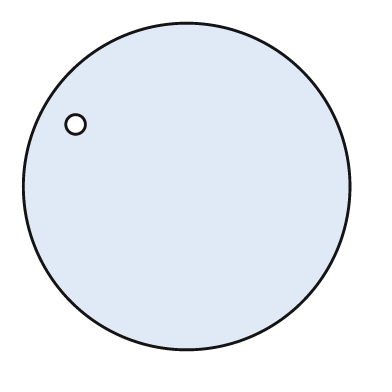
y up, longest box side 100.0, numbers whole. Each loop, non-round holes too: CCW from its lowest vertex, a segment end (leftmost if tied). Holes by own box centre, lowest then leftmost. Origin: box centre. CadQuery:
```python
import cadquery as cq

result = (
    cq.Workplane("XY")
    .moveTo(0.0, 0.0)
    .circle(50.0)
    .moveTo(-34.0, 19.0)
    .circle(3.0)
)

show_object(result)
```